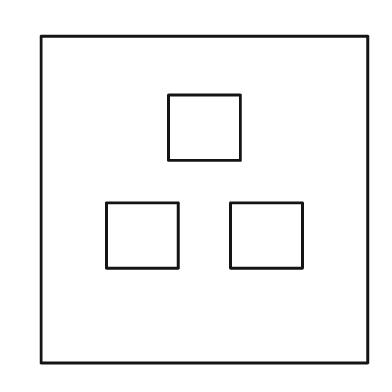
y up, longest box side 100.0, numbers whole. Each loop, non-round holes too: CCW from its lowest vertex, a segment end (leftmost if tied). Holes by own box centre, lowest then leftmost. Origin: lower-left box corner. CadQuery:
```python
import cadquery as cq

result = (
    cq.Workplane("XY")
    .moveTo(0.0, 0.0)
    .lineTo(100.0, 0.0)
    .lineTo(100.0, 100.0)
    .lineTo(0.0, 100.0)
    .close()
    .moveTo(20.0, 29.0)
    .lineTo(42.0, 29.0)
    .lineTo(42.0, 49.0)
    .lineTo(20.0, 49.0)
    .close()
    .moveTo(58.0, 29.0)
    .lineTo(80.0, 29.0)
    .lineTo(80.0, 49.0)
    .lineTo(58.0, 49.0)
    .close()
    .moveTo(39.0, 62.0)
    .lineTo(61.0, 62.0)
    .lineTo(61.0, 82.0)
    .lineTo(39.0, 82.0)
    .close()
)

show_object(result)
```